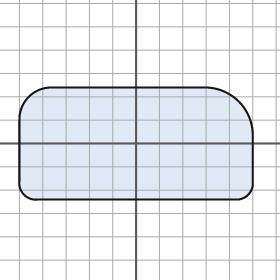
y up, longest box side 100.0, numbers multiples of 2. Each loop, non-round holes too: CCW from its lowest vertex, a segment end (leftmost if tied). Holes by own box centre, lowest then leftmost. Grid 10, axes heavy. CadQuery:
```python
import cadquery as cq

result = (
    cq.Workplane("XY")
    .moveTo(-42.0, -24.0)
    .lineTo(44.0, -24.0)
    .threePointArc((48.0, -22.0), (50.0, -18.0))
    .lineTo(50.0, 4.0)
    .threePointArc((44.0, 18.0), (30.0, 24.0))
    .lineTo(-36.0, 24.0)
    .threePointArc((-46.0, 20.0), (-50.0, 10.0))
    .lineTo(-50.0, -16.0)
    .threePointArc((-48.0, -22.0), (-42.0, -24.0))
    .close()
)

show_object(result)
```